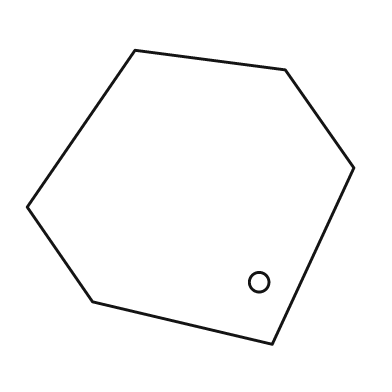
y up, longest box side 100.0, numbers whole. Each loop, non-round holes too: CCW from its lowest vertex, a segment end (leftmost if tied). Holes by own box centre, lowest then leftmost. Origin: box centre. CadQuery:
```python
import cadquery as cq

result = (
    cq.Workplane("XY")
    .moveTo(25.0, -45.0)
    .lineTo(50.0, 9.0)
    .lineTo(29.0, 39.0)
    .lineTo(-17.0, 45.0)
    .lineTo(-50.0, -3.0)
    .lineTo(-30.0, -32.0)
    .close()
    .moveTo(21.0, -26.0)
    .circle(3.0)
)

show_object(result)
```